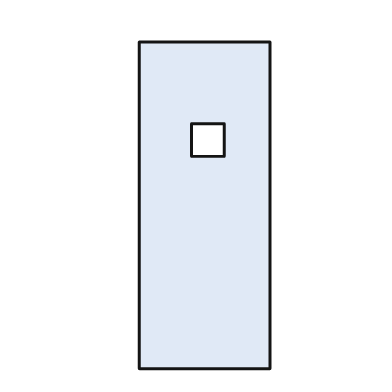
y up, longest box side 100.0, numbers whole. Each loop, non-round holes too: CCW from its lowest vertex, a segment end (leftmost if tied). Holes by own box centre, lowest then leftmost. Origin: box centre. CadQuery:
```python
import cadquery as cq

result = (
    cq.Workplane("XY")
    .moveTo(-20.0, -50.0)
    .lineTo(20.0, -50.0)
    .lineTo(20.0, 50.0)
    .lineTo(-20.0, 50.0)
    .close()
    .moveTo(-4.0, 15.0)
    .lineTo(6.0, 15.0)
    .lineTo(6.0, 25.0)
    .lineTo(-4.0, 25.0)
    .close()
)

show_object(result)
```